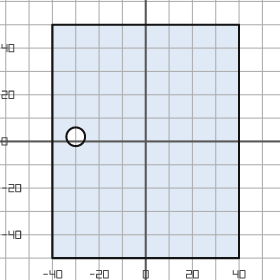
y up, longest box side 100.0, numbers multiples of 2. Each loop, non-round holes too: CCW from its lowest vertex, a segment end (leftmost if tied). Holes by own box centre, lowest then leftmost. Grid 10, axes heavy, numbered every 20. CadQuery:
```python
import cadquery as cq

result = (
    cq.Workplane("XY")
    .moveTo(-40.0, -50.0)
    .lineTo(40.0, -50.0)
    .lineTo(40.0, 50.0)
    .lineTo(-40.0, 50.0)
    .close()
    .moveTo(-30.0, 2.0)
    .circle(4.0)
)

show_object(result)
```